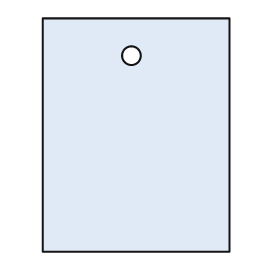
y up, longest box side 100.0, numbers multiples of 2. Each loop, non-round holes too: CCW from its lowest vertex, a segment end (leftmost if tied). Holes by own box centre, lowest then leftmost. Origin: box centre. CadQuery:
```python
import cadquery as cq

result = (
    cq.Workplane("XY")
    .moveTo(-40.0, -50.0)
    .lineTo(40.0, -50.0)
    .lineTo(40.0, 50.0)
    .lineTo(-40.0, 50.0)
    .close()
    .moveTo(-2.0, 34.0)
    .circle(4.0)
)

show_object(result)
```